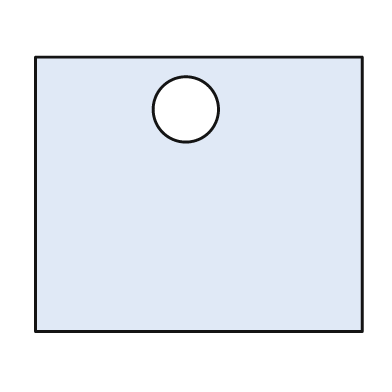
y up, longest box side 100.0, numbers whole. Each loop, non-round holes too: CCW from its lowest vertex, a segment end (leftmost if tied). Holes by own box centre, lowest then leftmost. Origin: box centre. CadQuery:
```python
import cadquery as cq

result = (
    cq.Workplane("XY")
    .moveTo(-50.0, -42.0)
    .lineTo(50.0, -42.0)
    .lineTo(50.0, 42.0)
    .lineTo(-50.0, 42.0)
    .close()
    .moveTo(-4.0, 26.0)
    .circle(10.0)
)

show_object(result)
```